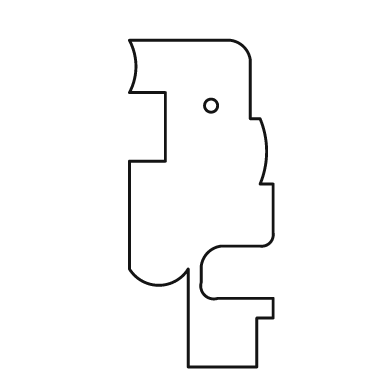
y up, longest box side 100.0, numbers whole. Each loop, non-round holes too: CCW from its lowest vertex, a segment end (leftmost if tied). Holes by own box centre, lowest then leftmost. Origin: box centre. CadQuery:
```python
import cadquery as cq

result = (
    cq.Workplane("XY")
    .moveTo(-4.0, -50.0)
    .lineTo(17.0, -50.0)
    .lineTo(17.0, -35.0)
    .lineTo(22.0, -35.0)
    .lineTo(22.0, -29.0)
    .lineTo(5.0, -29.0)
    .threePointArc((1.0, -28.0), (0.0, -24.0))
    .lineTo(0.0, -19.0)
    .threePointArc((2.0, -15.0), (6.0, -13.0))
    .lineTo(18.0, -13.0)
    .threePointArc((21.0, -12.0), (22.0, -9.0))
    .lineTo(22.0, 6.0)
    .lineTo(18.0, 6.0)
    .threePointArc((20.0, 16.0), (18.0, 26.0))
    .lineTo(15.0, 26.0)
    .lineTo(15.0, 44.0)
    .threePointArc((13.0, 48.0), (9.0, 50.0))
    .lineTo(-22.0, 50.0)
    .threePointArc((-20.0, 42.0), (-22.0, 34.0))
    .lineTo(-11.0, 34.0)
    .lineTo(-11.0, 13.0)
    .lineTo(-22.0, 13.0)
    .lineTo(-22.0, -20.0)
    .threePointArc((-13.0, -25.0), (-4.0, -20.0))
    .close()
    .moveTo(3.0, 30.0)
    .circle(2.0)
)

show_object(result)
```